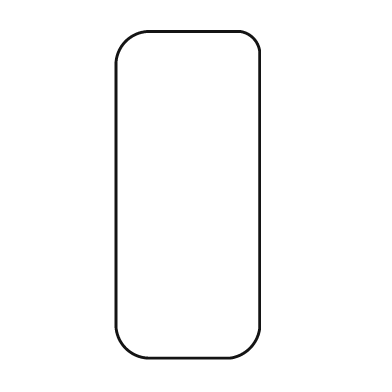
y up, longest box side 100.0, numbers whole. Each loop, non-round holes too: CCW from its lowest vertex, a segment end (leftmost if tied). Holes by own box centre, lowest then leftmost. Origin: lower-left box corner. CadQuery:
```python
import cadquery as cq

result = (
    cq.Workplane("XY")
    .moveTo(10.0, 0.0)
    .lineTo(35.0, 0.0)
    .threePointArc((41.0, 3.0), (44.0, 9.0))
    .lineTo(44.0, 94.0)
    .threePointArc((42.0, 98.0), (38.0, 100.0))
    .lineTo(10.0, 100.0)
    .threePointArc((3.0, 97.0), (0.0, 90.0))
    .lineTo(0.0, 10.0)
    .threePointArc((3.0, 3.0), (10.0, 0.0))
    .close()
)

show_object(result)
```